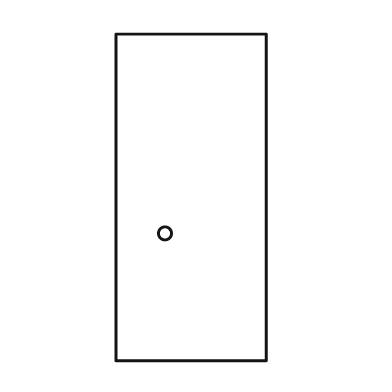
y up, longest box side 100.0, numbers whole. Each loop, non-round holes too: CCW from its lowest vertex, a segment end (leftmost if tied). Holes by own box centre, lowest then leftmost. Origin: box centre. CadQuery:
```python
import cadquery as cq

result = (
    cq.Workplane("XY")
    .moveTo(-23.0, -50.0)
    .lineTo(23.0, -50.0)
    .lineTo(23.0, 50.0)
    .lineTo(-23.0, 50.0)
    .close()
    .moveTo(-8.0, -11.0)
    .circle(2.0)
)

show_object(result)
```